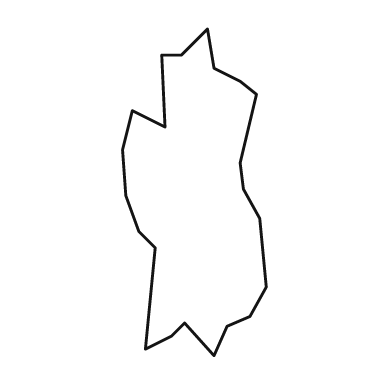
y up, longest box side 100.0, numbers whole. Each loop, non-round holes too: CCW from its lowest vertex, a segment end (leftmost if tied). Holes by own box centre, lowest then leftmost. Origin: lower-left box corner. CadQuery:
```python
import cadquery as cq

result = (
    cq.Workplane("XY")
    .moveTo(28.0, 0.0)
    .lineTo(32.0, 9.0)
    .lineTo(39.0, 12.0)
    .lineTo(44.0, 21.0)
    .lineTo(42.0, 42.0)
    .lineTo(37.0, 51.0)
    .lineTo(36.0, 59.0)
    .lineTo(41.0, 80.0)
    .lineTo(36.0, 84.0)
    .lineTo(28.0, 88.0)
    .lineTo(26.0, 100.0)
    .lineTo(18.0, 92.0)
    .lineTo(12.0, 92.0)
    .lineTo(13.0, 70.0)
    .lineTo(3.0, 75.0)
    .lineTo(0.0, 63.0)
    .lineTo(1.0, 49.0)
    .lineTo(5.0, 38.0)
    .lineTo(10.0, 33.0)
    .lineTo(7.0, 2.0)
    .lineTo(15.0, 6.0)
    .lineTo(19.0, 10.0)
    .close()
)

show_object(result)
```